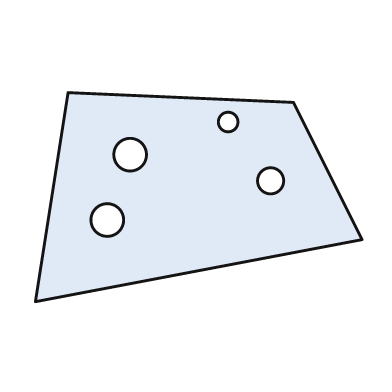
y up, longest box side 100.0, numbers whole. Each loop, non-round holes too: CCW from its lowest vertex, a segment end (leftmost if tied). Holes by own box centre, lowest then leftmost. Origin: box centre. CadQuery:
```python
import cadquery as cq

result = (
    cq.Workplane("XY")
    .moveTo(-50.0, -32.0)
    .lineTo(50.0, -13.0)
    .lineTo(29.0, 29.0)
    .lineTo(-40.0, 32.0)
    .close()
    .moveTo(-28.0, -7.0)
    .circle(5.0)
    .moveTo(22.0, 5.0)
    .circle(4.0)
    .moveTo(-21.0, 13.0)
    .circle(5.0)
    .moveTo(9.0, 23.0)
    .circle(3.0)
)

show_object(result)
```